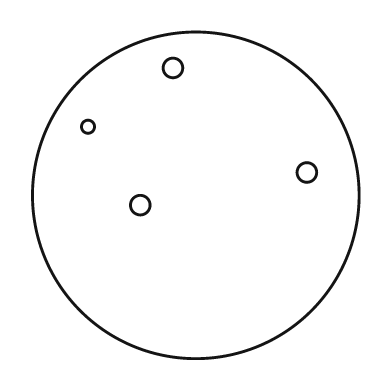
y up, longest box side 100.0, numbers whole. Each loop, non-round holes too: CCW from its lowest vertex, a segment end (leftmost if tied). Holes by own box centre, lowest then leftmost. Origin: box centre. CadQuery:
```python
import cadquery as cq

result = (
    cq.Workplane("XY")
    .moveTo(0.0, 0.0)
    .circle(50.0)
    .moveTo(-17.0, -3.0)
    .circle(3.0)
    .moveTo(34.0, 7.0)
    .circle(3.0)
    .moveTo(-33.0, 21.0)
    .circle(2.0)
    .moveTo(-7.0, 39.0)
    .circle(3.0)
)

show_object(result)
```